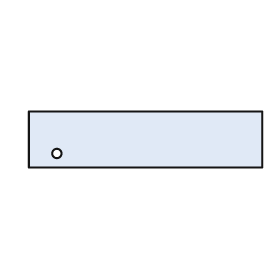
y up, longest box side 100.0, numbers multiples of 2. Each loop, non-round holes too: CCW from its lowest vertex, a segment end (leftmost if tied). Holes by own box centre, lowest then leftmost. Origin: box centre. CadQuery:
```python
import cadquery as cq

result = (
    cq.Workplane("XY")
    .moveTo(-50.0, -12.0)
    .lineTo(50.0, -12.0)
    .lineTo(50.0, 12.0)
    .lineTo(-50.0, 12.0)
    .close()
    .moveTo(-38.0, -6.0)
    .circle(2.0)
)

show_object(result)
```